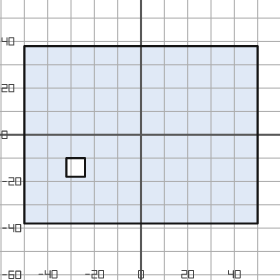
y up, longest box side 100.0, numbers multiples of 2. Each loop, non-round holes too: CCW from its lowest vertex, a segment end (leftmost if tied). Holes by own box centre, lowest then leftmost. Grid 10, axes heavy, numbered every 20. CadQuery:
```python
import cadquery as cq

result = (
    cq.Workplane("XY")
    .moveTo(-50.0, -38.0)
    .lineTo(50.0, -38.0)
    .lineTo(50.0, 38.0)
    .lineTo(-50.0, 38.0)
    .close()
    .moveTo(-32.0, -18.0)
    .lineTo(-24.0, -18.0)
    .lineTo(-24.0, -10.0)
    .lineTo(-32.0, -10.0)
    .close()
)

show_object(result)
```